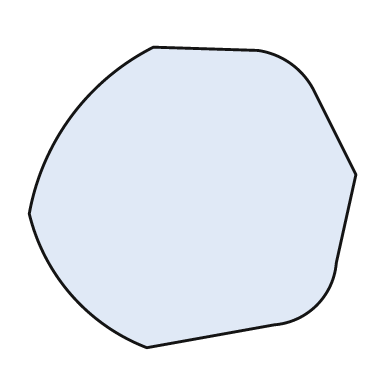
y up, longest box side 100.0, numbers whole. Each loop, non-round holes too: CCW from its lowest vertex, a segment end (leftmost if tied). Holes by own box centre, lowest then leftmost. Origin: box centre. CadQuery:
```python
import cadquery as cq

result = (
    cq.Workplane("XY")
    .moveTo(-14.0, -46.0)
    .lineTo(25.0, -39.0)
    .threePointArc((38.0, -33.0), (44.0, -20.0))
    .lineTo(50.0, 7.0)
    .lineTo(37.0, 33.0)
    .threePointArc((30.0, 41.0), (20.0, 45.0))
    .lineTo(-12.0, 46.0)
    .threePointArc((-37.0, 25.0), (-50.0, -5.0))
    .threePointArc((-37.0, -30.0), (-14.0, -46.0))
    .close()
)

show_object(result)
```